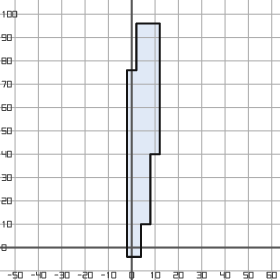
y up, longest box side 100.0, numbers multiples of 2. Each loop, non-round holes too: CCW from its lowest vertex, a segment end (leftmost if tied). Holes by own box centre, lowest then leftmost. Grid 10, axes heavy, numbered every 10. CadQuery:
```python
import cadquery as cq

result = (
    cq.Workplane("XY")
    .moveTo(-2.0, -4.0)
    .lineTo(4.0, -4.0)
    .lineTo(4.0, 10.0)
    .lineTo(8.0, 10.0)
    .lineTo(8.0, 40.0)
    .lineTo(12.0, 40.0)
    .lineTo(12.0, 96.0)
    .lineTo(2.0, 96.0)
    .lineTo(2.0, 76.0)
    .lineTo(-2.0, 76.0)
    .close()
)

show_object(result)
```